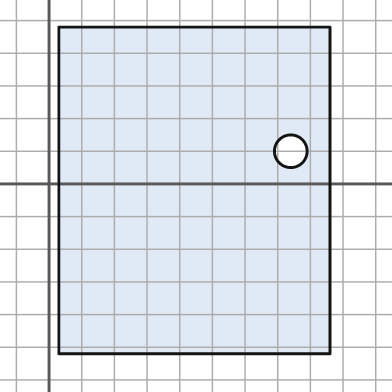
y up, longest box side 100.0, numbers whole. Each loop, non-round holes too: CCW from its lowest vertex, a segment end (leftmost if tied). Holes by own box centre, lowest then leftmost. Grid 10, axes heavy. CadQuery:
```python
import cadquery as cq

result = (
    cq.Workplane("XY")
    .moveTo(3.0, -52.0)
    .lineTo(86.0, -52.0)
    .lineTo(86.0, 48.0)
    .lineTo(3.0, 48.0)
    .close()
    .moveTo(74.0, 10.0)
    .circle(5.0)
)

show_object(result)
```